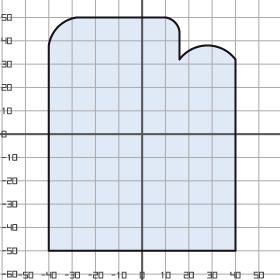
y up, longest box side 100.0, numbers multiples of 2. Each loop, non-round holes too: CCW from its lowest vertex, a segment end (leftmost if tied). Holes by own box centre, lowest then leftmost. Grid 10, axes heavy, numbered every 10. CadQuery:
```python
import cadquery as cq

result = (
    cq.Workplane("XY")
    .moveTo(-40.0, -50.0)
    .lineTo(40.0, -50.0)
    .lineTo(40.0, 32.0)
    .threePointArc((28.0, 38.0), (16.0, 32.0))
    .lineTo(16.0, 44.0)
    .threePointArc((14.0, 48.0), (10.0, 50.0))
    .lineTo(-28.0, 50.0)
    .threePointArc((-36.0, 46.0), (-40.0, 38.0))
    .close()
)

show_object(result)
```